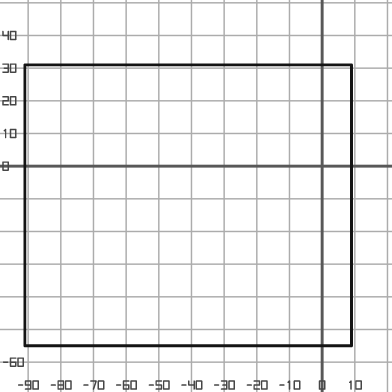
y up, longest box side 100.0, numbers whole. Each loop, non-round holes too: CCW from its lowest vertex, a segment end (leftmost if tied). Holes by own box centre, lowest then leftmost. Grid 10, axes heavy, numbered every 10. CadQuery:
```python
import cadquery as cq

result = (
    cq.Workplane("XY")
    .moveTo(-91.0, -55.0)
    .lineTo(9.0, -55.0)
    .lineTo(9.0, 31.0)
    .lineTo(-91.0, 31.0)
    .close()
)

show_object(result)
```